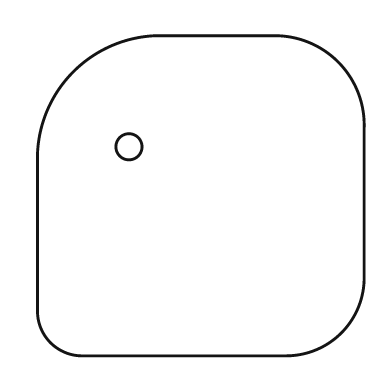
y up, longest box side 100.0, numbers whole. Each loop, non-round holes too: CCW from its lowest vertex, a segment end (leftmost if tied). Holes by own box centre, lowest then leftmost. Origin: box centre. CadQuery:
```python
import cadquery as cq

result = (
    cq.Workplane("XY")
    .moveTo(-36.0, -49.0)
    .lineTo(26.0, -49.0)
    .threePointArc((43.0, -42.0), (50.0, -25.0))
    .lineTo(50.0, 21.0)
    .threePointArc((42.0, 41.0), (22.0, 49.0))
    .lineTo(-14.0, 49.0)
    .threePointArc((-39.0, 38.0), (-50.0, 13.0))
    .lineTo(-50.0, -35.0)
    .threePointArc((-46.0, -45.0), (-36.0, -49.0))
    .close()
    .moveTo(-22.0, 15.0)
    .circle(4.0)
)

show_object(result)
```